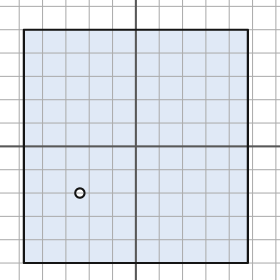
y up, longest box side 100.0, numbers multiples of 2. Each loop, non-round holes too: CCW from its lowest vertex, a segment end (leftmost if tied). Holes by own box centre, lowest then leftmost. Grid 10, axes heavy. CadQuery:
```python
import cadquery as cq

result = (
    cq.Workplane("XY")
    .moveTo(-48.0, -50.0)
    .lineTo(48.0, -50.0)
    .lineTo(48.0, 50.0)
    .lineTo(-48.0, 50.0)
    .close()
    .moveTo(-24.0, -20.0)
    .circle(2.0)
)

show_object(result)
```